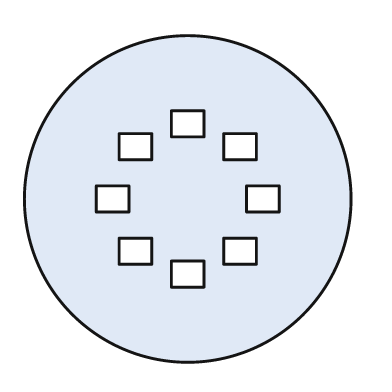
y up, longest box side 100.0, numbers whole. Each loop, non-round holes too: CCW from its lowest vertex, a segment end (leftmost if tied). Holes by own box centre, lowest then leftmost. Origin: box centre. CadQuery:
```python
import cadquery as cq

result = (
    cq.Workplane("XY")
    .moveTo(0.0, 0.0)
    .circle(50.0)
    .moveTo(-5.0, -27.0)
    .lineTo(5.0, -27.0)
    .lineTo(5.0, -19.0)
    .lineTo(-5.0, -19.0)
    .close()
    .moveTo(-21.0, -20.0)
    .lineTo(-11.0, -20.0)
    .lineTo(-11.0, -12.0)
    .lineTo(-21.0, -12.0)
    .close()
    .moveTo(11.0, -20.0)
    .lineTo(21.0, -20.0)
    .lineTo(21.0, -12.0)
    .lineTo(11.0, -12.0)
    .close()
    .moveTo(-28.0, -4.0)
    .lineTo(-18.0, -4.0)
    .lineTo(-18.0, 4.0)
    .lineTo(-28.0, 4.0)
    .close()
    .moveTo(18.0, -4.0)
    .lineTo(28.0, -4.0)
    .lineTo(28.0, 4.0)
    .lineTo(18.0, 4.0)
    .close()
    .moveTo(-21.0, 12.0)
    .lineTo(-11.0, 12.0)
    .lineTo(-11.0, 20.0)
    .lineTo(-21.0, 20.0)
    .close()
    .moveTo(11.0, 12.0)
    .lineTo(21.0, 12.0)
    .lineTo(21.0, 20.0)
    .lineTo(11.0, 20.0)
    .close()
    .moveTo(-5.0, 19.0)
    .lineTo(5.0, 19.0)
    .lineTo(5.0, 27.0)
    .lineTo(-5.0, 27.0)
    .close()
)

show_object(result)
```